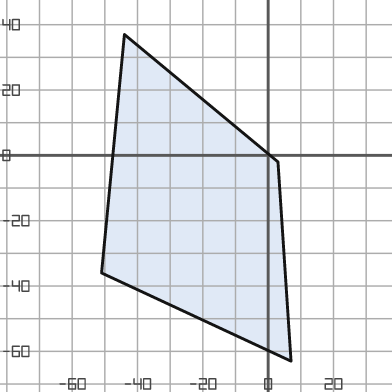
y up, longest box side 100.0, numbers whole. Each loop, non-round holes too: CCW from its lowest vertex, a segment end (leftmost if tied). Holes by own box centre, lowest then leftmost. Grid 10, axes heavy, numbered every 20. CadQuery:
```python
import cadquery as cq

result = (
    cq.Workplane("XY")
    .moveTo(7.0, -63.0)
    .lineTo(3.0, -2.0)
    .lineTo(-44.0, 37.0)
    .lineTo(-51.0, -36.0)
    .close()
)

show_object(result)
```